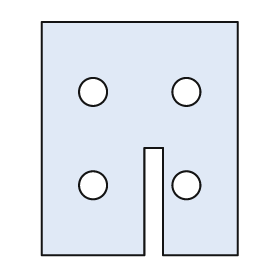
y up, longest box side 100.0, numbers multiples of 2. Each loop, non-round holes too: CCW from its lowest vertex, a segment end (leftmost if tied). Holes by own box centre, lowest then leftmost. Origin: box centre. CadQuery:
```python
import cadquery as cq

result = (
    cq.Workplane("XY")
    .moveTo(-42.0, -50.0)
    .lineTo(2.0, -50.0)
    .lineTo(2.0, -4.0)
    .lineTo(10.0, -4.0)
    .lineTo(10.0, -50.0)
    .lineTo(42.0, -50.0)
    .lineTo(42.0, 50.0)
    .lineTo(-42.0, 50.0)
    .close()
    .moveTo(-20.0, -20.0)
    .circle(6.0)
    .moveTo(20.0, -20.0)
    .circle(6.0)
    .moveTo(-20.0, 20.0)
    .circle(6.0)
    .moveTo(20.0, 20.0)
    .circle(6.0)
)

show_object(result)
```